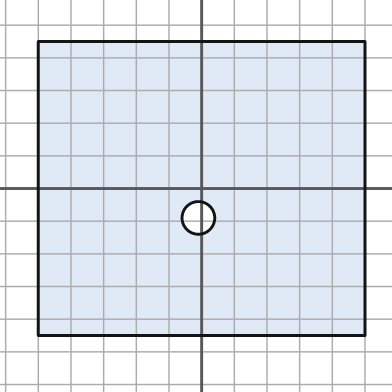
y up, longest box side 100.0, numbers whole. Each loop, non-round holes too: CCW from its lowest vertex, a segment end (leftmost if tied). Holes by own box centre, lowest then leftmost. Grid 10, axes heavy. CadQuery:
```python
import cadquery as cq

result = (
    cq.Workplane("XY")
    .moveTo(-50.0, -45.0)
    .lineTo(50.0, -45.0)
    .lineTo(50.0, 45.0)
    .lineTo(-50.0, 45.0)
    .close()
    .moveTo(-1.0, -9.0)
    .circle(5.0)
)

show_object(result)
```